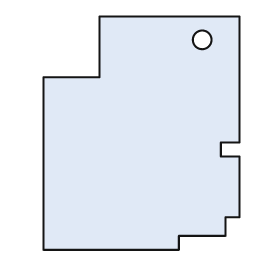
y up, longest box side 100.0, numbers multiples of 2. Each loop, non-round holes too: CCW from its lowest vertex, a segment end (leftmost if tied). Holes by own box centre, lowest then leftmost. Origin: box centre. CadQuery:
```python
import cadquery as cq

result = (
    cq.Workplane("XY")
    .moveTo(-42.0, -50.0)
    .lineTo(16.0, -50.0)
    .lineTo(16.0, -44.0)
    .lineTo(36.0, -44.0)
    .lineTo(36.0, -36.0)
    .lineTo(42.0, -36.0)
    .lineTo(42.0, -10.0)
    .lineTo(34.0, -10.0)
    .lineTo(34.0, -4.0)
    .lineTo(42.0, -4.0)
    .lineTo(42.0, 50.0)
    .lineTo(-18.0, 50.0)
    .lineTo(-18.0, 24.0)
    .lineTo(-42.0, 24.0)
    .close()
    .moveTo(26.0, 40.0)
    .circle(4.0)
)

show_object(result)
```